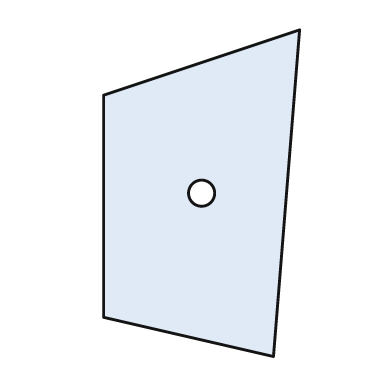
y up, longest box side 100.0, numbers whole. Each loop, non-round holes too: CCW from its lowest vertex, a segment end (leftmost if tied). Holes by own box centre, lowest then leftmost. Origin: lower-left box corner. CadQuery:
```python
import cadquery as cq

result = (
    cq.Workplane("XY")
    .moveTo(52.0, 0.0)
    .lineTo(60.0, 100.0)
    .lineTo(0.0, 80.0)
    .lineTo(0.0, 12.0)
    .close()
    .moveTo(30.0, 50.0)
    .circle(4.0)
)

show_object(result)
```